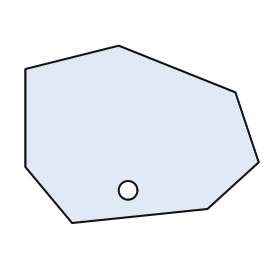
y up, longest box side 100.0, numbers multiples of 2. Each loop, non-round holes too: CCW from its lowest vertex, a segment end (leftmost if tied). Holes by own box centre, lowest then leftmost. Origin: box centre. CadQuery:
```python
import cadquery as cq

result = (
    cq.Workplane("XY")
    .moveTo(-30.0, -38.0)
    .lineTo(28.0, -32.0)
    .lineTo(50.0, -12.0)
    .lineTo(40.0, 18.0)
    .lineTo(-10.0, 38.0)
    .lineTo(-50.0, 28.0)
    .lineTo(-50.0, -14.0)
    .close()
    .moveTo(-6.0, -24.0)
    .circle(4.0)
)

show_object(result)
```